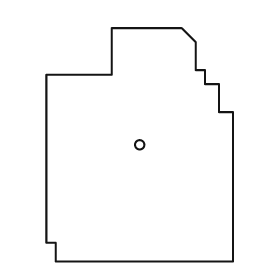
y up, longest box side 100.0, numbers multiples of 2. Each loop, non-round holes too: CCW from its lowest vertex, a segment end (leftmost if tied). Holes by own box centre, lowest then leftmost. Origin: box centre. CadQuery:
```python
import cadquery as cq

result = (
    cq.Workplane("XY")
    .moveTo(-36.0, -50.0)
    .lineTo(40.0, -50.0)
    .lineTo(40.0, 14.0)
    .lineTo(34.0, 14.0)
    .lineTo(34.0, 26.0)
    .lineTo(28.0, 26.0)
    .lineTo(28.0, 32.0)
    .lineTo(24.0, 32.0)
    .lineTo(24.0, 44.0)
    .lineTo(18.0, 50.0)
    .lineTo(-12.0, 50.0)
    .lineTo(-12.0, 30.0)
    .lineTo(-40.0, 30.0)
    .lineTo(-40.0, -42.0)
    .lineTo(-36.0, -42.0)
    .close()
    .moveTo(0.0, 0.0)
    .circle(2.0)
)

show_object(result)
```